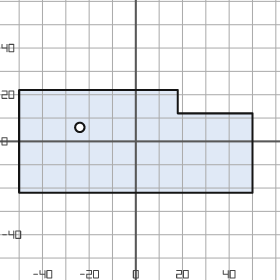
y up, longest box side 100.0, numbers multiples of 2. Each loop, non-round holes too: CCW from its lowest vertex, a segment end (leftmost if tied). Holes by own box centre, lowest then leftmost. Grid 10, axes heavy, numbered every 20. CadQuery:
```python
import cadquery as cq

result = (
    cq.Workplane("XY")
    .moveTo(-50.0, -22.0)
    .lineTo(50.0, -22.0)
    .lineTo(50.0, 12.0)
    .lineTo(18.0, 12.0)
    .lineTo(18.0, 22.0)
    .lineTo(-50.0, 22.0)
    .close()
    .moveTo(-24.0, 6.0)
    .circle(2.0)
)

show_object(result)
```